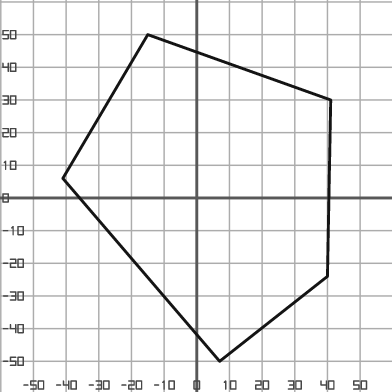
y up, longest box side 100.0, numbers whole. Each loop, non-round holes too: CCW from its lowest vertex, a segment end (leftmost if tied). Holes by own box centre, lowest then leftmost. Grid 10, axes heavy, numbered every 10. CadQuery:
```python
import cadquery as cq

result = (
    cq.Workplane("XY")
    .moveTo(7.0, -50.0)
    .lineTo(40.0, -24.0)
    .lineTo(41.0, 30.0)
    .lineTo(-15.0, 50.0)
    .lineTo(-41.0, 6.0)
    .close()
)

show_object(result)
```